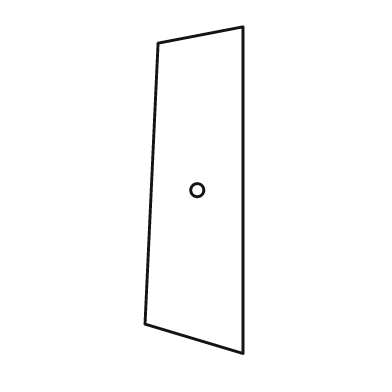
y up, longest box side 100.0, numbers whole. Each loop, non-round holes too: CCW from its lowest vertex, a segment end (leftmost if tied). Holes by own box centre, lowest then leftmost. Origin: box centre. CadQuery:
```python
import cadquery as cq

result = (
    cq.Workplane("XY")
    .moveTo(15.0, -50.0)
    .lineTo(15.0, 50.0)
    .lineTo(-11.0, 45.0)
    .lineTo(-15.0, -41.0)
    .close()
    .moveTo(1.0, 0.0)
    .circle(2.0)
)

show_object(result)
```